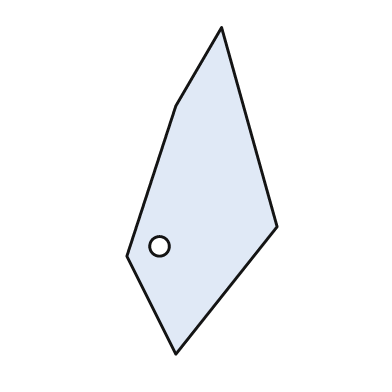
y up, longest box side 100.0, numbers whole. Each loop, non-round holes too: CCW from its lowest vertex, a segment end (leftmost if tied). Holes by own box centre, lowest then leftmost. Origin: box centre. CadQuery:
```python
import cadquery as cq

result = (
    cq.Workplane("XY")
    .moveTo(-8.0, -50.0)
    .lineTo(23.0, -11.0)
    .lineTo(6.0, 50.0)
    .lineTo(-8.0, 26.0)
    .lineTo(-23.0, -20.0)
    .close()
    .moveTo(-13.0, -17.0)
    .circle(3.0)
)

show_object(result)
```